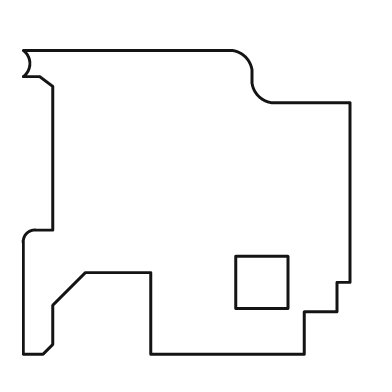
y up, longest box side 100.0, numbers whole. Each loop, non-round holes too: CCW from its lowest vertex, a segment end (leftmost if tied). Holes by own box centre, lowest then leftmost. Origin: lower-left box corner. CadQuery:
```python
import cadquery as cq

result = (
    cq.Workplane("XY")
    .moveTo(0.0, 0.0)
    .lineTo(6.0, 0.0)
    .lineTo(9.0, 3.0)
    .lineTo(9.0, 15.0)
    .lineTo(19.0, 25.0)
    .lineTo(39.0, 25.0)
    .lineTo(39.0, 0.0)
    .lineTo(86.0, 0.0)
    .lineTo(86.0, 13.0)
    .lineTo(96.0, 13.0)
    .lineTo(96.0, 22.0)
    .lineTo(100.0, 22.0)
    .lineTo(100.0, 77.0)
    .lineTo(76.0, 77.0)
    .threePointArc((72.0, 79.0), (70.0, 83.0))
    .lineTo(70.0, 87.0)
    .threePointArc((68.0, 91.0), (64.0, 93.0))
    .lineTo(0.0, 93.0)
    .threePointArc((2.0, 89.0), (0.0, 85.0))
    .lineTo(5.0, 85.0)
    .lineTo(9.0, 82.0)
    .lineTo(9.0, 38.0)
    .lineTo(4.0, 38.0)
    .threePointArc((1.0, 37.0), (0.0, 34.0))
    .close()
    .moveTo(65.0, 14.0)
    .lineTo(81.0, 14.0)
    .lineTo(81.0, 30.0)
    .lineTo(65.0, 30.0)
    .close()
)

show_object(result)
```